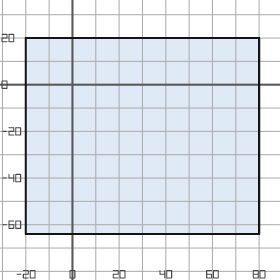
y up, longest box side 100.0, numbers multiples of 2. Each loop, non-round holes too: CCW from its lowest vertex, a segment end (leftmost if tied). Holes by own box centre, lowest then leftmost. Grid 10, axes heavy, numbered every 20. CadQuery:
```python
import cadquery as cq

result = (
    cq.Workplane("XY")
    .moveTo(-20.0, -64.0)
    .lineTo(80.0, -64.0)
    .lineTo(80.0, 20.0)
    .lineTo(-20.0, 20.0)
    .close()
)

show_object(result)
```